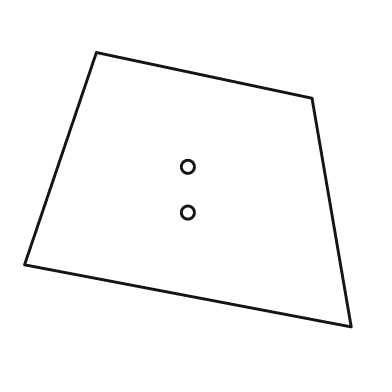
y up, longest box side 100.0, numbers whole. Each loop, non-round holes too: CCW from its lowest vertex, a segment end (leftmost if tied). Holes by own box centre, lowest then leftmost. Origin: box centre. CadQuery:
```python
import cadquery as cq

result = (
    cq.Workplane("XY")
    .moveTo(50.0, -42.0)
    .lineTo(38.0, 28.0)
    .lineTo(-28.0, 42.0)
    .lineTo(-50.0, -23.0)
    .close()
    .moveTo(0.0, -7.0)
    .circle(2.0)
    .moveTo(0.0, 7.0)
    .circle(2.0)
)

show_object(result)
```